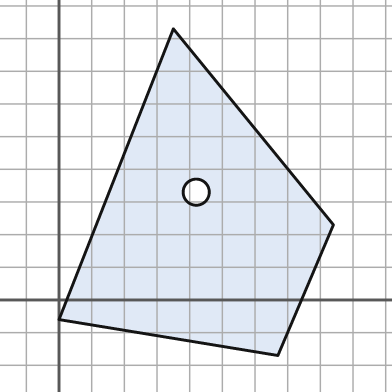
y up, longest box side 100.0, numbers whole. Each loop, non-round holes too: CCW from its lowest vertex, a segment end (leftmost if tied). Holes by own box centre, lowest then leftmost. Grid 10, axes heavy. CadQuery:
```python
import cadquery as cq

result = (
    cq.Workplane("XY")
    .moveTo(67.0, -17.0)
    .lineTo(84.0, 23.0)
    .lineTo(35.0, 83.0)
    .lineTo(0.0, -6.0)
    .close()
    .moveTo(42.0, 33.0)
    .circle(4.0)
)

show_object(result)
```